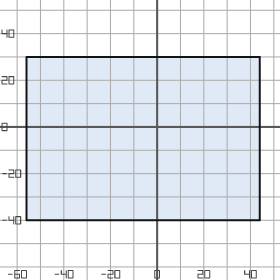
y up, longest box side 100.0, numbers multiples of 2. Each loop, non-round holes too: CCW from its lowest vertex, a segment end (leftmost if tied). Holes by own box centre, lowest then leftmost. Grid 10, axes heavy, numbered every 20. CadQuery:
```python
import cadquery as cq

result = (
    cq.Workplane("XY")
    .moveTo(-56.0, -40.0)
    .lineTo(44.0, -40.0)
    .lineTo(44.0, 30.0)
    .lineTo(-56.0, 30.0)
    .close()
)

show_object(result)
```